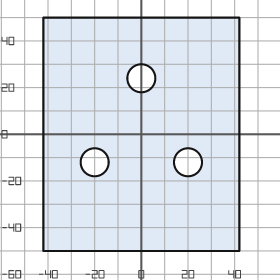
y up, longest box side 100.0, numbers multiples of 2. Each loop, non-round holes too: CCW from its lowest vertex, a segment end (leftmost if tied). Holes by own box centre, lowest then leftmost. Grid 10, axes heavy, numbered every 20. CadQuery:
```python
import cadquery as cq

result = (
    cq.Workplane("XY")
    .moveTo(-42.0, -50.0)
    .lineTo(42.0, -50.0)
    .lineTo(42.0, 50.0)
    .lineTo(-42.0, 50.0)
    .close()
    .moveTo(-20.0, -12.0)
    .circle(6.0)
    .moveTo(20.0, -12.0)
    .circle(6.0)
    .moveTo(0.0, 24.0)
    .circle(6.0)
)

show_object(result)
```